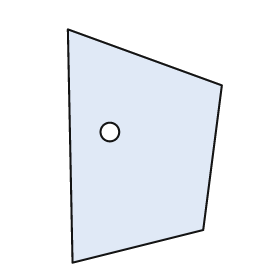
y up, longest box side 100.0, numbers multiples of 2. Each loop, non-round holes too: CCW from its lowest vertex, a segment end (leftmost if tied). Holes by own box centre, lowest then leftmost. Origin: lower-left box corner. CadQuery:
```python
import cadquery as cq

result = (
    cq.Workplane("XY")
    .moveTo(2.0, 0.0)
    .lineTo(58.0, 14.0)
    .lineTo(66.0, 76.0)
    .lineTo(0.0, 100.0)
    .close()
    .moveTo(18.0, 56.0)
    .circle(4.0)
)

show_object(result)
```